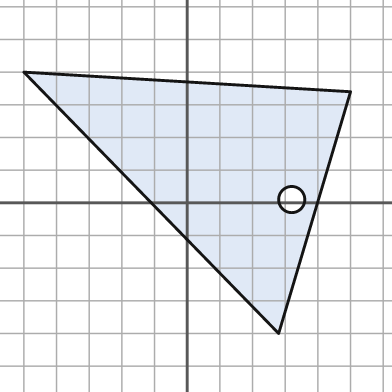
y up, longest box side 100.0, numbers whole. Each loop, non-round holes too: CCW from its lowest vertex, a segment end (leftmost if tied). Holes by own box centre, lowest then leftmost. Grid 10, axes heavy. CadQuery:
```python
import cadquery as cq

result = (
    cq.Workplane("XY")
    .moveTo(28.0, -40.0)
    .lineTo(50.0, 34.0)
    .lineTo(-50.0, 40.0)
    .close()
    .moveTo(32.0, 1.0)
    .circle(4.0)
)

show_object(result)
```